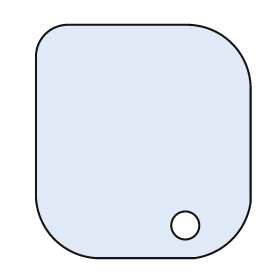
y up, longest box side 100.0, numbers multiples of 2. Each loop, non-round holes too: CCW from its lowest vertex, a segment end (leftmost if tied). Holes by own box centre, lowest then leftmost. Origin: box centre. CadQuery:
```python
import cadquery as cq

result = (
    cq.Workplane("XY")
    .moveTo(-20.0, -50.0)
    .lineTo(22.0, -50.0)
    .threePointArc((38.0, -42.0), (46.0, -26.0))
    .lineTo(46.0, 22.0)
    .threePointArc((38.0, 42.0), (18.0, 50.0))
    .lineTo(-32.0, 50.0)
    .threePointArc((-42.0, 46.0), (-46.0, 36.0))
    .lineTo(-46.0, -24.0)
    .threePointArc((-38.0, -42.0), (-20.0, -50.0))
    .close()
    .moveTo(18.0, -36.0)
    .circle(6.0)
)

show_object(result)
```